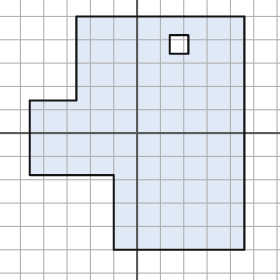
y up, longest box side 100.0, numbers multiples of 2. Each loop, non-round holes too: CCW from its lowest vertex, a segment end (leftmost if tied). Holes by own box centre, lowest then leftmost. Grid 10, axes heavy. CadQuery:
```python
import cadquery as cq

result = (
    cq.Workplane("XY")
    .moveTo(-10.0, -50.0)
    .lineTo(46.0, -50.0)
    .lineTo(46.0, 50.0)
    .lineTo(-26.0, 50.0)
    .lineTo(-26.0, 14.0)
    .lineTo(-46.0, 14.0)
    .lineTo(-46.0, -18.0)
    .lineTo(-10.0, -18.0)
    .close()
    .moveTo(14.0, 34.0)
    .lineTo(22.0, 34.0)
    .lineTo(22.0, 42.0)
    .lineTo(14.0, 42.0)
    .close()
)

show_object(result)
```